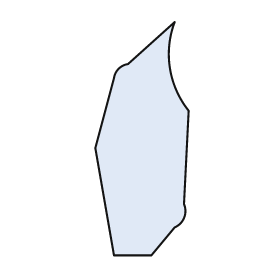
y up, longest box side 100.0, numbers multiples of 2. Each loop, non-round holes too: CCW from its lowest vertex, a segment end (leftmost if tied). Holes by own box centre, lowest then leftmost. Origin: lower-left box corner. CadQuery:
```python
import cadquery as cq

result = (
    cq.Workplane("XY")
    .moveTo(8.0, 0.0)
    .lineTo(24.0, 0.0)
    .lineTo(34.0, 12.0)
    .threePointArc((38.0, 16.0), (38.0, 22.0))
    .lineTo(40.0, 62.0)
    .threePointArc((32.0, 80.0), (34.0, 100.0))
    .lineTo(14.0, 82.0)
    .threePointArc((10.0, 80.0), (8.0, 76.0))
    .lineTo(0.0, 46.0)
    .close()
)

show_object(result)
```